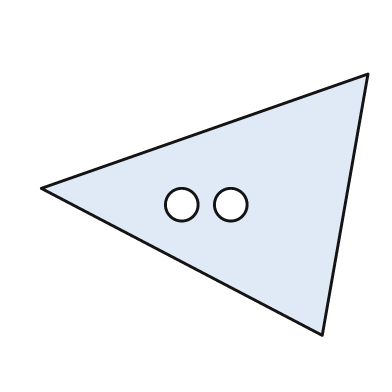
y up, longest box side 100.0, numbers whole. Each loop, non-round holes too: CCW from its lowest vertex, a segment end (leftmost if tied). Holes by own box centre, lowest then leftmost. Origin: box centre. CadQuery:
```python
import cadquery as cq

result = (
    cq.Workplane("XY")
    .moveTo(36.0, -40.0)
    .lineTo(50.0, 40.0)
    .lineTo(-50.0, 5.0)
    .close()
    .moveTo(-7.0, 0.0)
    .circle(5.0)
    .moveTo(8.0, 0.0)
    .circle(5.0)
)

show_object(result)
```